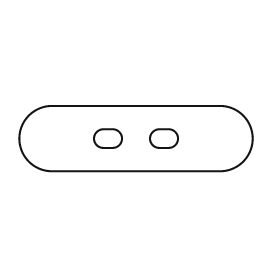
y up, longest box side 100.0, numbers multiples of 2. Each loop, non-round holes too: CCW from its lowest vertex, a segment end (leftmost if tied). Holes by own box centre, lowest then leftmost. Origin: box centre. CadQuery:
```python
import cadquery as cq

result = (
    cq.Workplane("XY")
    .moveTo(-36.0, -14.0)
    .lineTo(36.0, -14.0)
    .threePointArc((50.0, 0.0), (36.0, 14.0))
    .lineTo(-36.0, 14.0)
    .threePointArc((-50.0, 0.0), (-36.0, -14.0))
    .close()
    .moveTo(-14.0, -4.0)
    .lineTo(-10.0, -4.0)
    .threePointArc((-6.0, 0.0), (-10.0, 4.0))
    .lineTo(-14.0, 4.0)
    .threePointArc((-18.0, 0.0), (-14.0, -4.0))
    .close()
    .moveTo(10.0, -4.0)
    .lineTo(14.0, -4.0)
    .threePointArc((18.0, 0.0), (14.0, 4.0))
    .lineTo(10.0, 4.0)
    .threePointArc((6.0, 0.0), (10.0, -4.0))
    .close()
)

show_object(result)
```